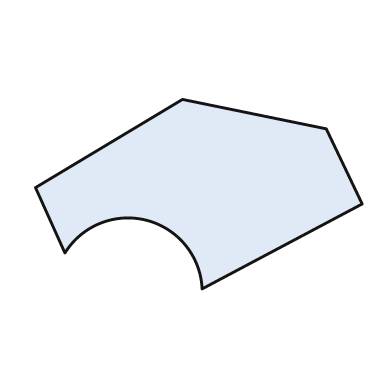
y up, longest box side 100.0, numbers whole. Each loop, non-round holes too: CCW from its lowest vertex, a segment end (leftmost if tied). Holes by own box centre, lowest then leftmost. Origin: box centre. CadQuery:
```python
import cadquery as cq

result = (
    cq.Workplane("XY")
    .moveTo(1.0, -29.0)
    .lineTo(50.0, -3.0)
    .lineTo(39.0, 20.0)
    .lineTo(-5.0, 29.0)
    .lineTo(-50.0, 2.0)
    .lineTo(-41.0, -18.0)
    .threePointArc((-16.0, -8.0), (1.0, -29.0))
    .close()
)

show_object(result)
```